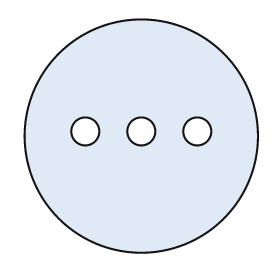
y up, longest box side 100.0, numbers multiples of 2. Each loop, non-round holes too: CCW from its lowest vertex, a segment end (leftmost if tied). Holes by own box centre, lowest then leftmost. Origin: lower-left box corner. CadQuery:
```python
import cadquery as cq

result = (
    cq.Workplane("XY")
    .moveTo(50.0, 50.0)
    .circle(50.0)
    .moveTo(26.0, 52.0)
    .circle(6.0)
    .moveTo(50.0, 52.0)
    .circle(6.0)
    .moveTo(74.0, 52.0)
    .circle(6.0)
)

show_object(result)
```